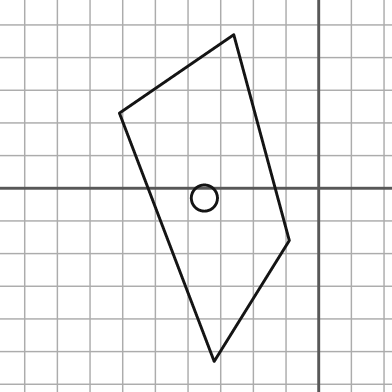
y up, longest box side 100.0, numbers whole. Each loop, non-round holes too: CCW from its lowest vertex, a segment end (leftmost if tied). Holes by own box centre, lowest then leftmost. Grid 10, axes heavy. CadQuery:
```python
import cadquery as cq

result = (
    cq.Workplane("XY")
    .moveTo(-32.0, -53.0)
    .lineTo(-9.0, -16.0)
    .lineTo(-26.0, 47.0)
    .lineTo(-61.0, 23.0)
    .close()
    .moveTo(-35.0, -3.0)
    .circle(4.0)
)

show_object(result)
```